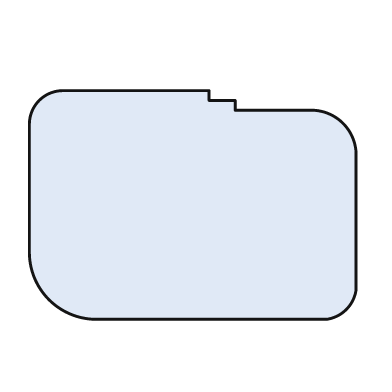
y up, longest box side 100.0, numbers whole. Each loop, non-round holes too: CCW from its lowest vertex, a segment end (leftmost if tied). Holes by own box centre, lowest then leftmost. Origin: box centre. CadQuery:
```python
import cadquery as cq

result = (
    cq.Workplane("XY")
    .moveTo(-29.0, -35.0)
    .lineTo(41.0, -35.0)
    .threePointArc((47.0, -32.0), (50.0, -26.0))
    .lineTo(50.0, 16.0)
    .threePointArc((46.0, 25.0), (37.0, 29.0))
    .lineTo(13.0, 29.0)
    .lineTo(13.0, 32.0)
    .lineTo(5.0, 32.0)
    .lineTo(5.0, 35.0)
    .lineTo(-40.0, 35.0)
    .threePointArc((-47.0, 32.0), (-50.0, 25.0))
    .lineTo(-50.0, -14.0)
    .threePointArc((-44.0, -29.0), (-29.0, -35.0))
    .close()
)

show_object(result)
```